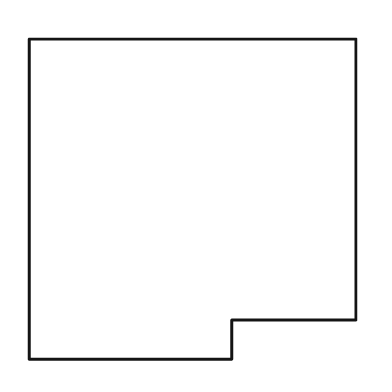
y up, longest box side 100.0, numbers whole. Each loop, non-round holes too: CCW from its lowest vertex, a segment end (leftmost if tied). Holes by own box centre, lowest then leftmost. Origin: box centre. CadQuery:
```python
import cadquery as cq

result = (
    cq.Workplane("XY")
    .moveTo(-50.0, -49.0)
    .lineTo(12.0, -49.0)
    .lineTo(12.0, -37.0)
    .lineTo(50.0, -37.0)
    .lineTo(50.0, 49.0)
    .lineTo(-50.0, 49.0)
    .close()
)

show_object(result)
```